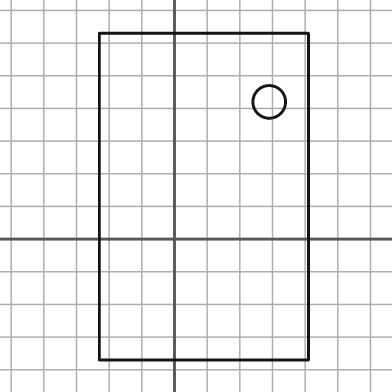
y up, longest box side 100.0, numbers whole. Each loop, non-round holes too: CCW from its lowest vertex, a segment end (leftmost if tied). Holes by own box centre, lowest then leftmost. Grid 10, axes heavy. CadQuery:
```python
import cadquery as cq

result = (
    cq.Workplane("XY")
    .moveTo(-23.0, -37.0)
    .lineTo(41.0, -37.0)
    .lineTo(41.0, 63.0)
    .lineTo(-23.0, 63.0)
    .close()
    .moveTo(29.0, 42.0)
    .circle(5.0)
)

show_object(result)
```